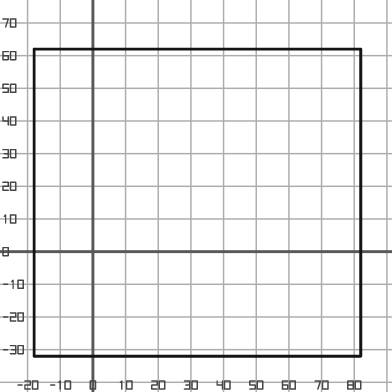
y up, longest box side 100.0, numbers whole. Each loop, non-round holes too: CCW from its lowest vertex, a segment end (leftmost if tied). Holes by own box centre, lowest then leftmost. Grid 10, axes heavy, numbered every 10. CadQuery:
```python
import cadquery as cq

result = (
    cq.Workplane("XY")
    .moveTo(-18.0, -32.0)
    .lineTo(82.0, -32.0)
    .lineTo(82.0, 62.0)
    .lineTo(-18.0, 62.0)
    .close()
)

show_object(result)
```